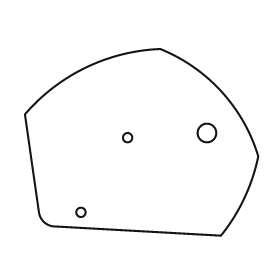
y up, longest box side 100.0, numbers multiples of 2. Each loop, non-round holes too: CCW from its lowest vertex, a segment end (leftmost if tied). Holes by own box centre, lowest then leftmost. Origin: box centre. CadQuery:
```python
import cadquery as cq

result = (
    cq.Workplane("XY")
    .moveTo(34.0, -40.0)
    .threePointArc((44.0, -24.0), (50.0, -6.0))
    .threePointArc((34.0, 22.0), (8.0, 40.0))
    .threePointArc((-24.0, 32.0), (-50.0, 12.0))
    .lineTo(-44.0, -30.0)
    .threePointArc((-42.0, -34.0), (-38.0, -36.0))
    .close()
    .moveTo(-26.0, -30.0)
    .circle(2.0)
    .moveTo(-6.0, 2.0)
    .circle(2.0)
    .moveTo(28.0, 4.0)
    .circle(4.0)
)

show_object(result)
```